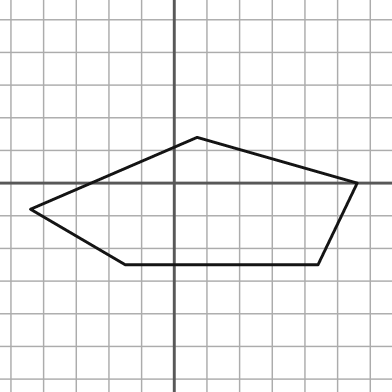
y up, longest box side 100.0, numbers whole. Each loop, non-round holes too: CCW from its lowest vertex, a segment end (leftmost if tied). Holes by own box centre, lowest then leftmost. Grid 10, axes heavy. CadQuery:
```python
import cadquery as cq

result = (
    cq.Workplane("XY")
    .moveTo(-15.0, -25.0)
    .lineTo(44.0, -25.0)
    .lineTo(56.0, 0.0)
    .lineTo(7.0, 14.0)
    .lineTo(-44.0, -8.0)
    .close()
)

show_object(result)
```